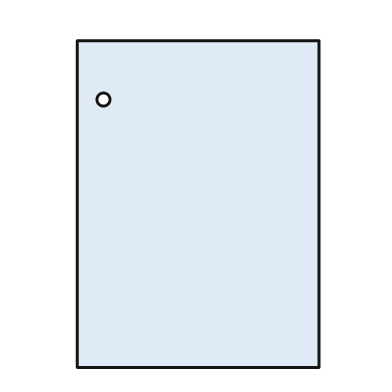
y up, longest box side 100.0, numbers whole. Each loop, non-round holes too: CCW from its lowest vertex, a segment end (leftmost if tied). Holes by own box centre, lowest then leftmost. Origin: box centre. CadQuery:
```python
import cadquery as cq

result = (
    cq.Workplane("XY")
    .moveTo(-37.0, -50.0)
    .lineTo(37.0, -50.0)
    .lineTo(37.0, 50.0)
    .lineTo(-37.0, 50.0)
    .close()
    .moveTo(-29.0, 32.0)
    .circle(2.0)
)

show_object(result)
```